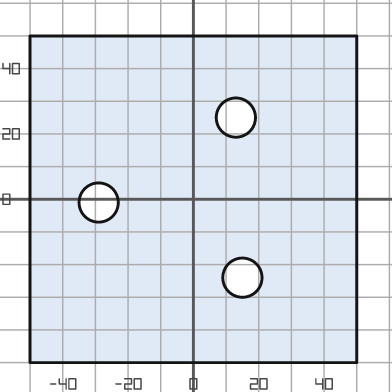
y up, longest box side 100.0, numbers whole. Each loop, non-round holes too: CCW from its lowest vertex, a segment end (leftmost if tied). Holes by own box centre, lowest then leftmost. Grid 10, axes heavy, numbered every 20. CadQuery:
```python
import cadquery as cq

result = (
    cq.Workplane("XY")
    .moveTo(-50.0, -50.0)
    .lineTo(50.0, -50.0)
    .lineTo(50.0, 50.0)
    .lineTo(-50.0, 50.0)
    .close()
    .moveTo(15.0, -24.0)
    .circle(6.0)
    .moveTo(-29.0, -1.0)
    .circle(6.0)
    .moveTo(13.0, 25.0)
    .circle(6.0)
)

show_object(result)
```